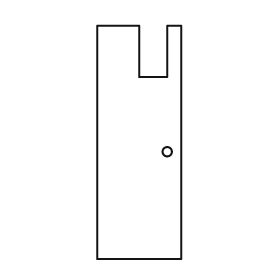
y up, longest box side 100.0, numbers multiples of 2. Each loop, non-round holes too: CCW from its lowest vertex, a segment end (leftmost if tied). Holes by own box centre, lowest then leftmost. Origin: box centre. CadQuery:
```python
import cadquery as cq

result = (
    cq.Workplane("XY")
    .moveTo(-18.0, -50.0)
    .lineTo(18.0, -50.0)
    .lineTo(18.0, 50.0)
    .lineTo(12.0, 50.0)
    .lineTo(12.0, 28.0)
    .lineTo(0.0, 28.0)
    .lineTo(0.0, 50.0)
    .lineTo(-18.0, 50.0)
    .close()
    .moveTo(12.0, -4.0)
    .circle(2.0)
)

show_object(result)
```